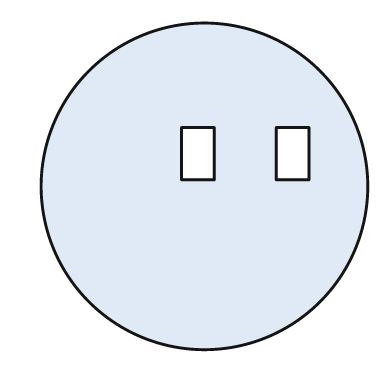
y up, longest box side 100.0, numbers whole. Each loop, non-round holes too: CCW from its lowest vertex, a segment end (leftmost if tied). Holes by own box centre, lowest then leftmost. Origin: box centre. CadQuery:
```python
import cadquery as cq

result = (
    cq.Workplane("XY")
    .moveTo(0.0, 0.0)
    .circle(50.0)
    .moveTo(-7.0, 2.0)
    .lineTo(3.0, 2.0)
    .lineTo(3.0, 18.0)
    .lineTo(-7.0, 18.0)
    .close()
    .moveTo(22.0, 2.0)
    .lineTo(32.0, 2.0)
    .lineTo(32.0, 18.0)
    .lineTo(22.0, 18.0)
    .close()
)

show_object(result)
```